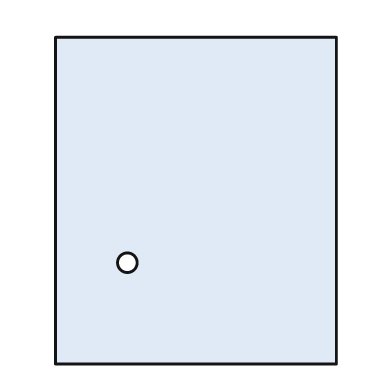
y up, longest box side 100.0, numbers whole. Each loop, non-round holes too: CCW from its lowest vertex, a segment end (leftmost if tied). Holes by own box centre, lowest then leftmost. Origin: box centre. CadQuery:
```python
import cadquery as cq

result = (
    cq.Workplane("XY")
    .moveTo(-43.0, -50.0)
    .lineTo(43.0, -50.0)
    .lineTo(43.0, 50.0)
    .lineTo(-43.0, 50.0)
    .close()
    .moveTo(-21.0, -19.0)
    .circle(3.0)
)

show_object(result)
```